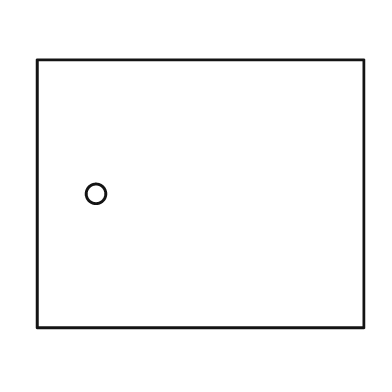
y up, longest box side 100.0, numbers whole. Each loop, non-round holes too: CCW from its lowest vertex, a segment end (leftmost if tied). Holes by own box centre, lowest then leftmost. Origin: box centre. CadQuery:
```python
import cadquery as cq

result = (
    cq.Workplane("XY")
    .moveTo(-50.0, -41.0)
    .lineTo(50.0, -41.0)
    .lineTo(50.0, 41.0)
    .lineTo(-50.0, 41.0)
    .close()
    .moveTo(-32.0, 0.0)
    .circle(3.0)
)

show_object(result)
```